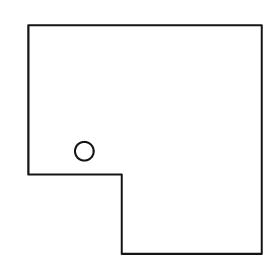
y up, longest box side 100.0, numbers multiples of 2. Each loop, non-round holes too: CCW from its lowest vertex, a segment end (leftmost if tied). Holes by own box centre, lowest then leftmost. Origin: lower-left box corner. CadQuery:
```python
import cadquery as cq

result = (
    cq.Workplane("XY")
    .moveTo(40.0, 0.0)
    .lineTo(100.0, 0.0)
    .lineTo(100.0, 98.0)
    .lineTo(0.0, 98.0)
    .lineTo(0.0, 34.0)
    .lineTo(40.0, 34.0)
    .close()
    .moveTo(24.0, 44.0)
    .circle(4.0)
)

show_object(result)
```